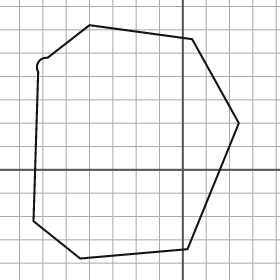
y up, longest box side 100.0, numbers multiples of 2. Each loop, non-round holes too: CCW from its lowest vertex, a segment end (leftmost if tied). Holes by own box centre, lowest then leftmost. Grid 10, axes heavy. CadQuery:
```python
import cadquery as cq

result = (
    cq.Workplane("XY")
    .moveTo(-44.0, -38.0)
    .lineTo(2.0, -34.0)
    .lineTo(24.0, 20.0)
    .lineTo(4.0, 56.0)
    .lineTo(-40.0, 62.0)
    .lineTo(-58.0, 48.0)
    .threePointArc((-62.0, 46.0), (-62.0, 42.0))
    .lineTo(-64.0, -22.0)
    .close()
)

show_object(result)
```